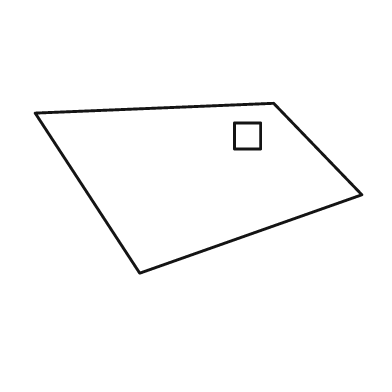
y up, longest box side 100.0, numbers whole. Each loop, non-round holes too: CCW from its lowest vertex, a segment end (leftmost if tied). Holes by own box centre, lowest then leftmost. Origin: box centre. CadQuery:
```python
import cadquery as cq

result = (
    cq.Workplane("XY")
    .moveTo(-18.0, -26.0)
    .lineTo(50.0, -2.0)
    .lineTo(23.0, 26.0)
    .lineTo(-50.0, 23.0)
    .close()
    .moveTo(11.0, 12.0)
    .lineTo(19.0, 12.0)
    .lineTo(19.0, 20.0)
    .lineTo(11.0, 20.0)
    .close()
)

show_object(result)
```